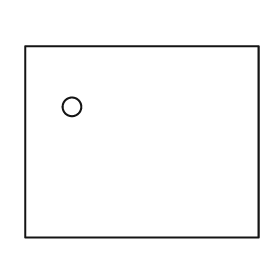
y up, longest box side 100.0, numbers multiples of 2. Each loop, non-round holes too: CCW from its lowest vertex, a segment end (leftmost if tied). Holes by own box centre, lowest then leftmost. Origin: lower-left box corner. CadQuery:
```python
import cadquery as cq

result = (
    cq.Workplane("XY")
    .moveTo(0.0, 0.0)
    .lineTo(100.0, 0.0)
    .lineTo(100.0, 82.0)
    .lineTo(0.0, 82.0)
    .close()
    .moveTo(20.0, 56.0)
    .circle(4.0)
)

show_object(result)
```